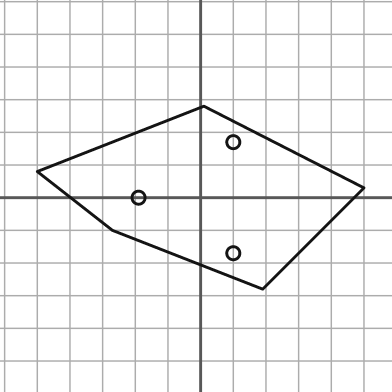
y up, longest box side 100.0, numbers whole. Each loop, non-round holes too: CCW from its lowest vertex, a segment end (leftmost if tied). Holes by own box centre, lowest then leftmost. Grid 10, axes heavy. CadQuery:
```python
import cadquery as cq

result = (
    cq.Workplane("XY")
    .moveTo(19.0, -28.0)
    .lineTo(50.0, 3.0)
    .lineTo(1.0, 28.0)
    .lineTo(-50.0, 8.0)
    .lineTo(-27.0, -10.0)
    .close()
    .moveTo(10.0, -17.0)
    .circle(2.0)
    .moveTo(-19.0, 0.0)
    .circle(2.0)
    .moveTo(10.0, 17.0)
    .circle(2.0)
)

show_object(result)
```